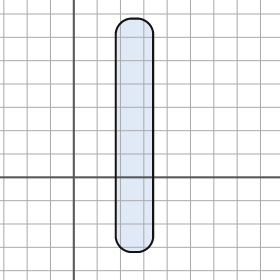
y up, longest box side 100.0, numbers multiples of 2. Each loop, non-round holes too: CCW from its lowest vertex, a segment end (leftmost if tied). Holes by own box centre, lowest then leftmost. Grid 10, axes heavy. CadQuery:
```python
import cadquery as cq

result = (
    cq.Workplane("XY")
    .moveTo(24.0, -32.0)
    .lineTo(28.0, -32.0)
    .threePointArc((32.0, -30.0), (34.0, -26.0))
    .lineTo(34.0, 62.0)
    .threePointArc((32.0, 66.0), (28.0, 68.0))
    .lineTo(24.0, 68.0)
    .threePointArc((20.0, 66.0), (18.0, 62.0))
    .lineTo(18.0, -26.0)
    .threePointArc((20.0, -30.0), (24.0, -32.0))
    .close()
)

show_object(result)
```